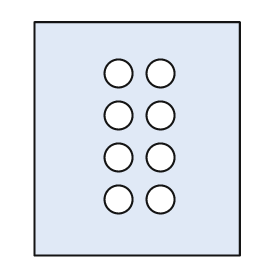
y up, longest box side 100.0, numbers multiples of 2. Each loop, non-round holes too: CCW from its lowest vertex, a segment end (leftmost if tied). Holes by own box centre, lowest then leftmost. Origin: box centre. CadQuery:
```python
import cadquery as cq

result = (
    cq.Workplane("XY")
    .moveTo(-44.0, -50.0)
    .lineTo(44.0, -50.0)
    .lineTo(44.0, 50.0)
    .lineTo(-44.0, 50.0)
    .close()
    .moveTo(-8.0, -26.0)
    .circle(6.0)
    .moveTo(10.0, -26.0)
    .circle(6.0)
    .moveTo(-8.0, -8.0)
    .circle(6.0)
    .moveTo(10.0, -8.0)
    .circle(6.0)
    .moveTo(-8.0, 10.0)
    .circle(6.0)
    .moveTo(10.0, 10.0)
    .circle(6.0)
    .moveTo(-8.0, 28.0)
    .circle(6.0)
    .moveTo(10.0, 28.0)
    .circle(6.0)
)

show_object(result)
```